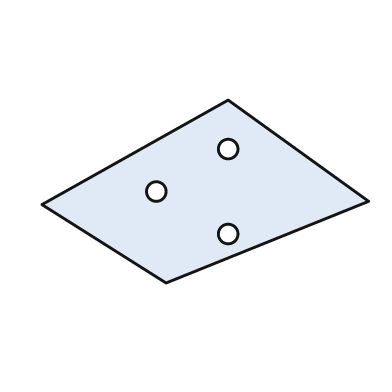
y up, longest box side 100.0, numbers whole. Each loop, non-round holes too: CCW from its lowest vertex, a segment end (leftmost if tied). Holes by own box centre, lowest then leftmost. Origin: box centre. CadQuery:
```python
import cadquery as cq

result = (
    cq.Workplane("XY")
    .moveTo(-12.0, -28.0)
    .lineTo(50.0, -3.0)
    .lineTo(7.0, 28.0)
    .lineTo(-50.0, -4.0)
    .close()
    .moveTo(7.0, -13.0)
    .circle(3.0)
    .moveTo(-15.0, 0.0)
    .circle(3.0)
    .moveTo(7.0, 13.0)
    .circle(3.0)
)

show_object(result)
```